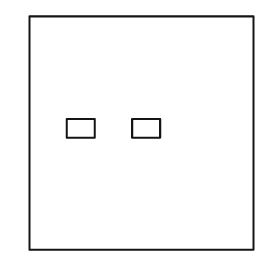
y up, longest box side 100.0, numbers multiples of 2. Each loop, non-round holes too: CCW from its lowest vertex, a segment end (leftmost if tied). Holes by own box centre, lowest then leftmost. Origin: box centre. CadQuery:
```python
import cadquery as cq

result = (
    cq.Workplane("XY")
    .moveTo(-48.0, -50.0)
    .lineTo(48.0, -50.0)
    .lineTo(48.0, 50.0)
    .lineTo(-48.0, 50.0)
    .close()
    .moveTo(-32.0, -2.0)
    .lineTo(-20.0, -2.0)
    .lineTo(-20.0, 6.0)
    .lineTo(-32.0, 6.0)
    .close()
    .moveTo(-4.0, -2.0)
    .lineTo(8.0, -2.0)
    .lineTo(8.0, 6.0)
    .lineTo(-4.0, 6.0)
    .close()
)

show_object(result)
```